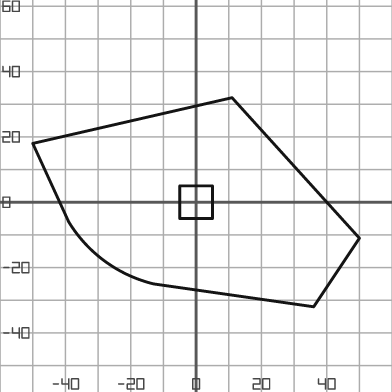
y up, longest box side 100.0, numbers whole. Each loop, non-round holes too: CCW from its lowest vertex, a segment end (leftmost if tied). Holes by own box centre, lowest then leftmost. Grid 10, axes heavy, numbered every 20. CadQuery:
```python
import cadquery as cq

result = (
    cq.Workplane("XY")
    .moveTo(36.0, -32.0)
    .lineTo(50.0, -11.0)
    .lineTo(11.0, 32.0)
    .lineTo(-50.0, 18.0)
    .lineTo(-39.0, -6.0)
    .threePointArc((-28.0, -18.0), (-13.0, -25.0))
    .close()
    .moveTo(-5.0, -5.0)
    .lineTo(5.0, -5.0)
    .lineTo(5.0, 5.0)
    .lineTo(-5.0, 5.0)
    .close()
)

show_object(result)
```